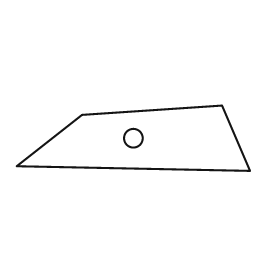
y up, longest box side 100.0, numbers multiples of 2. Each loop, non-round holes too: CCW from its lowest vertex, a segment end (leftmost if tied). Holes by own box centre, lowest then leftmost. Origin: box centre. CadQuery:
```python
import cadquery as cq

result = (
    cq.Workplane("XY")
    .moveTo(50.0, -14.0)
    .lineTo(38.0, 14.0)
    .lineTo(-22.0, 10.0)
    .lineTo(-50.0, -12.0)
    .close()
    .moveTo(0.0, 0.0)
    .circle(4.0)
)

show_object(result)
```